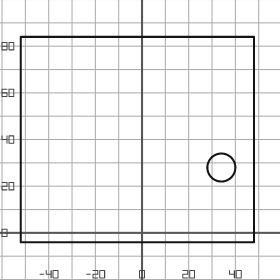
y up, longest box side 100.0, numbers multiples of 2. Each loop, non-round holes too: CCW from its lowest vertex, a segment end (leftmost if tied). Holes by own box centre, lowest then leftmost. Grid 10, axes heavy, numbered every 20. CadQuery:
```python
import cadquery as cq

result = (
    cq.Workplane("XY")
    .moveTo(-52.0, -4.0)
    .lineTo(48.0, -4.0)
    .lineTo(48.0, 84.0)
    .lineTo(-52.0, 84.0)
    .close()
    .moveTo(34.0, 28.0)
    .circle(6.0)
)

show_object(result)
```